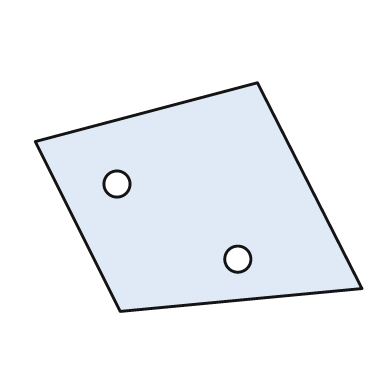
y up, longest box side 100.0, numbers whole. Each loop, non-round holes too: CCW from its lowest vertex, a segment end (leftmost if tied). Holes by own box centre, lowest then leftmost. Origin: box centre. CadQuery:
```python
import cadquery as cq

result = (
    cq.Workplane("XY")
    .moveTo(-24.0, -35.0)
    .lineTo(50.0, -28.0)
    .lineTo(18.0, 35.0)
    .lineTo(-50.0, 17.0)
    .close()
    .moveTo(12.0, -19.0)
    .circle(4.0)
    .moveTo(-25.0, 4.0)
    .circle(4.0)
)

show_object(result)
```